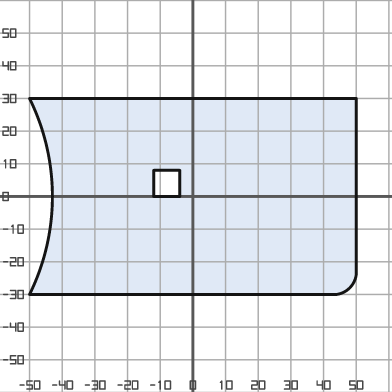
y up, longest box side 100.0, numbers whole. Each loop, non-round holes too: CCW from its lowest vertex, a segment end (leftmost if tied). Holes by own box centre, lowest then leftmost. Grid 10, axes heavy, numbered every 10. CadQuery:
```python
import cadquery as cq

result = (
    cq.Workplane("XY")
    .moveTo(-50.0, -30.0)
    .lineTo(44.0, -30.0)
    .threePointArc((48.0, -28.0), (50.0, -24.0))
    .lineTo(50.0, 30.0)
    .lineTo(-50.0, 30.0)
    .threePointArc((-43.0, 0.0), (-50.0, -30.0))
    .close()
    .moveTo(-12.0, 0.0)
    .lineTo(-4.0, 0.0)
    .lineTo(-4.0, 8.0)
    .lineTo(-12.0, 8.0)
    .close()
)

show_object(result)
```